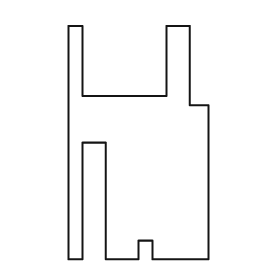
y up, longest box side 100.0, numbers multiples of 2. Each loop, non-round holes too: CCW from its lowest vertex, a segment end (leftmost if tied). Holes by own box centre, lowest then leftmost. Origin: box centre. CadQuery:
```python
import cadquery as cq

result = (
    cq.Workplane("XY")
    .moveTo(-30.0, -50.0)
    .lineTo(-24.0, -50.0)
    .lineTo(-24.0, 0.0)
    .lineTo(-14.0, 0.0)
    .lineTo(-14.0, -50.0)
    .lineTo(0.0, -50.0)
    .lineTo(0.0, -42.0)
    .lineTo(6.0, -42.0)
    .lineTo(6.0, -50.0)
    .lineTo(30.0, -50.0)
    .lineTo(30.0, 16.0)
    .lineTo(22.0, 16.0)
    .lineTo(22.0, 50.0)
    .lineTo(12.0, 50.0)
    .lineTo(12.0, 20.0)
    .lineTo(-24.0, 20.0)
    .lineTo(-24.0, 50.0)
    .lineTo(-30.0, 50.0)
    .close()
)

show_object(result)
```